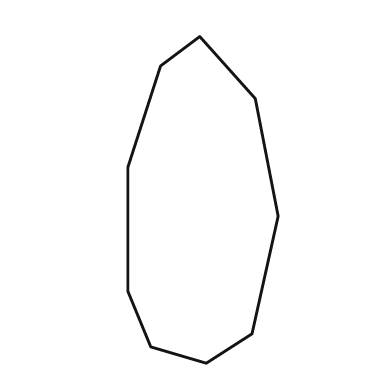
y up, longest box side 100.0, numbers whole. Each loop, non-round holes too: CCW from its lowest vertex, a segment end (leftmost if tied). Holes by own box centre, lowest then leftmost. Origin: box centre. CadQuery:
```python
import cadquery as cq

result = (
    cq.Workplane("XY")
    .moveTo(1.0, -50.0)
    .lineTo(15.0, -41.0)
    .lineTo(23.0, -5.0)
    .lineTo(16.0, 31.0)
    .lineTo(-1.0, 50.0)
    .lineTo(-13.0, 41.0)
    .lineTo(-23.0, 10.0)
    .lineTo(-23.0, -28.0)
    .lineTo(-16.0, -45.0)
    .close()
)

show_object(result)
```